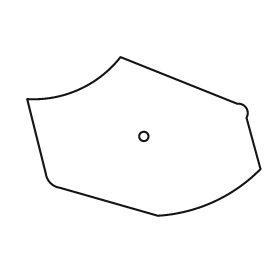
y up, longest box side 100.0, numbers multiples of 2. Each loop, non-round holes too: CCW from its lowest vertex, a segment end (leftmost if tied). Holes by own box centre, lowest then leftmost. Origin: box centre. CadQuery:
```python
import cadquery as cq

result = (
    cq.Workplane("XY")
    .moveTo(6.0, -34.0)
    .threePointArc((30.0, -28.0), (50.0, -14.0))
    .lineTo(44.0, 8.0)
    .threePointArc((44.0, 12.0), (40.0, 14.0))
    .lineTo(-10.0, 34.0)
    .threePointArc((-28.0, 20.0), (-50.0, 16.0))
    .lineTo(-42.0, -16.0)
    .threePointArc((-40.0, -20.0), (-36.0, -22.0))
    .close()
    .moveTo(0.0, 0.0)
    .circle(2.0)
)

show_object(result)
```